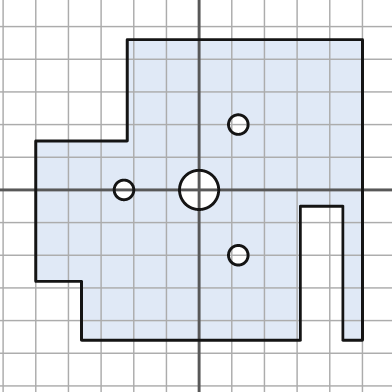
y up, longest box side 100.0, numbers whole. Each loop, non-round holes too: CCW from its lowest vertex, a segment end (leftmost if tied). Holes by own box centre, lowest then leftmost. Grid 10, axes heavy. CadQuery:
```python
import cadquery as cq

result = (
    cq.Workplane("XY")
    .moveTo(-36.0, -46.0)
    .lineTo(31.0, -46.0)
    .lineTo(31.0, -5.0)
    .lineTo(44.0, -5.0)
    .lineTo(44.0, -46.0)
    .lineTo(50.0, -46.0)
    .lineTo(50.0, 46.0)
    .lineTo(-22.0, 46.0)
    .lineTo(-22.0, 15.0)
    .lineTo(-50.0, 15.0)
    .lineTo(-50.0, -28.0)
    .lineTo(-36.0, -28.0)
    .close()
    .moveTo(12.0, -20.0)
    .circle(3.0)
    .moveTo(-23.0, 0.0)
    .circle(3.0)
    .moveTo(0.0, 0.0)
    .circle(6.0)
    .moveTo(12.0, 20.0)
    .circle(3.0)
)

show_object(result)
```